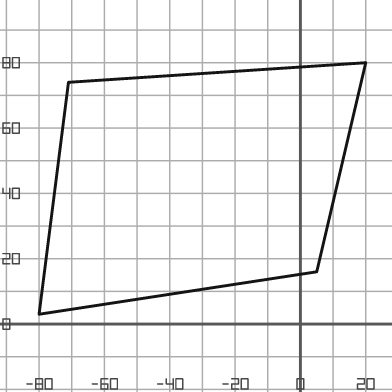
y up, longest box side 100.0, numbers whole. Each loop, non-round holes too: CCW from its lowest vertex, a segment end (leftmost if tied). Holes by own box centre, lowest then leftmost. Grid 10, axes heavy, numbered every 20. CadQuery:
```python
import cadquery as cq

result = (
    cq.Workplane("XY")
    .moveTo(-80.0, 3.0)
    .lineTo(5.0, 16.0)
    .lineTo(20.0, 80.0)
    .lineTo(-71.0, 74.0)
    .close()
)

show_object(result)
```